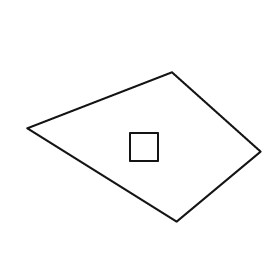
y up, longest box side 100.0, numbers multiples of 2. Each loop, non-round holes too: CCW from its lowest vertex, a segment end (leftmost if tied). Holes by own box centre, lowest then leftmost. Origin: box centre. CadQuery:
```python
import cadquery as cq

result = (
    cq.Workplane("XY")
    .moveTo(14.0, -32.0)
    .lineTo(50.0, -2.0)
    .lineTo(12.0, 32.0)
    .lineTo(-50.0, 8.0)
    .close()
    .moveTo(-6.0, -6.0)
    .lineTo(6.0, -6.0)
    .lineTo(6.0, 6.0)
    .lineTo(-6.0, 6.0)
    .close()
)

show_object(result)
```